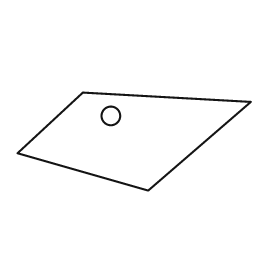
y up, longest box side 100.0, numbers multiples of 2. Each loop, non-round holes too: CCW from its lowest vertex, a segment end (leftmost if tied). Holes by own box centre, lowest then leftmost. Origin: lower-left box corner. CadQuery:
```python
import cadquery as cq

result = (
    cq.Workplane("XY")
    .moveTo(56.0, 0.0)
    .lineTo(100.0, 38.0)
    .lineTo(28.0, 42.0)
    .lineTo(0.0, 16.0)
    .close()
    .moveTo(40.0, 32.0)
    .circle(4.0)
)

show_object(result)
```